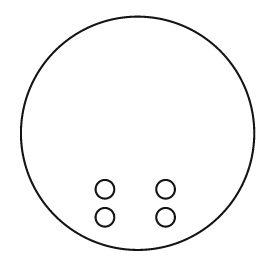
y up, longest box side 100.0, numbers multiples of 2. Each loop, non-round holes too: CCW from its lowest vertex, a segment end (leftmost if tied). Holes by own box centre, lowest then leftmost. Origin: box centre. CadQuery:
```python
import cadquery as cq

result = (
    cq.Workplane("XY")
    .moveTo(0.0, 0.0)
    .circle(50.0)
    .moveTo(-14.0, -36.0)
    .circle(4.0)
    .moveTo(12.0, -36.0)
    .circle(4.0)
    .moveTo(-14.0, -24.0)
    .circle(4.0)
    .moveTo(12.0, -24.0)
    .circle(4.0)
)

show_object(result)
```